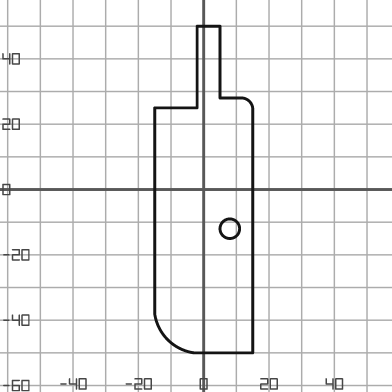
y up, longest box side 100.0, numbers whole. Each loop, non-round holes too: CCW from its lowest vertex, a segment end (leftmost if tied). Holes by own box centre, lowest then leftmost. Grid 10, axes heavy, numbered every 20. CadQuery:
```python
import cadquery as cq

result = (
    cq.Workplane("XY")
    .moveTo(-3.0, -50.0)
    .lineTo(15.0, -50.0)
    .lineTo(15.0, 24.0)
    .threePointArc((14.0, 27.0), (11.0, 28.0))
    .lineTo(5.0, 28.0)
    .lineTo(5.0, 50.0)
    .lineTo(-2.0, 50.0)
    .lineTo(-2.0, 25.0)
    .lineTo(-15.0, 25.0)
    .lineTo(-15.0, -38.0)
    .threePointArc((-11.0, -46.0), (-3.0, -50.0))
    .close()
    .moveTo(8.0, -12.0)
    .circle(3.0)
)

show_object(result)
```